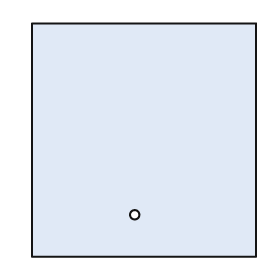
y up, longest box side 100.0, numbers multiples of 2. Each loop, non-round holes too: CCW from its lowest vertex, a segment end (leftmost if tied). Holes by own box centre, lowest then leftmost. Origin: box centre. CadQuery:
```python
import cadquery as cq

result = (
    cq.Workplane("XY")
    .moveTo(-48.0, -50.0)
    .lineTo(48.0, -50.0)
    .lineTo(48.0, 50.0)
    .lineTo(-48.0, 50.0)
    .close()
    .moveTo(-4.0, -32.0)
    .circle(2.0)
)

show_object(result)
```